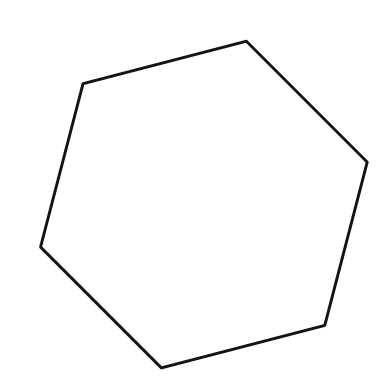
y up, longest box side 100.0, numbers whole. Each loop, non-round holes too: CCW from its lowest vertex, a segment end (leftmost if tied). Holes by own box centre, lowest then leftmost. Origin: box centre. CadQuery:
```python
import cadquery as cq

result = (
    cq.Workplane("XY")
    .moveTo(-13.0, -50.0)
    .lineTo(37.0, -37.0)
    .lineTo(50.0, 13.0)
    .lineTo(13.0, 50.0)
    .lineTo(-37.0, 37.0)
    .lineTo(-50.0, -13.0)
    .close()
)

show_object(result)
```